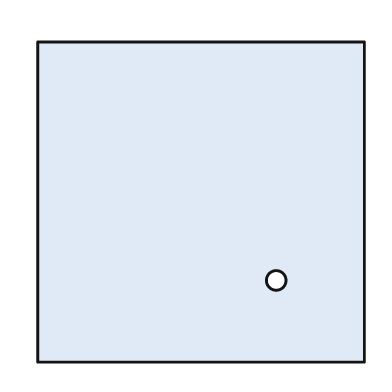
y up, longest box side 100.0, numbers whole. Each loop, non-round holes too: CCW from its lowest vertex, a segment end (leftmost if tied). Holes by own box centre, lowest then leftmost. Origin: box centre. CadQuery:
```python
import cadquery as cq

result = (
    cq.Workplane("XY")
    .moveTo(-50.0, -49.0)
    .lineTo(50.0, -49.0)
    .lineTo(50.0, 49.0)
    .lineTo(-50.0, 49.0)
    .close()
    .moveTo(23.0, -24.0)
    .circle(3.0)
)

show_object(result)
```